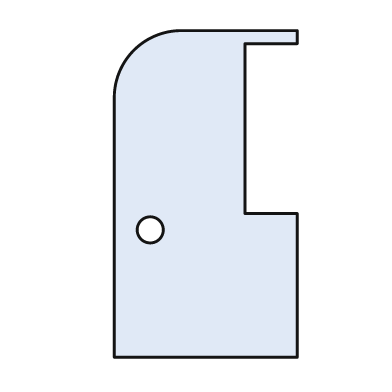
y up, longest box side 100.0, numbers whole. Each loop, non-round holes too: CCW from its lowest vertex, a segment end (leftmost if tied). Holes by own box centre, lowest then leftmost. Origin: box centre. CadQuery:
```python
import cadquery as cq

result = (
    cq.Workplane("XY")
    .moveTo(-28.0, -50.0)
    .lineTo(28.0, -50.0)
    .lineTo(28.0, -6.0)
    .lineTo(12.0, -6.0)
    .lineTo(12.0, 46.0)
    .lineTo(28.0, 46.0)
    .lineTo(28.0, 50.0)
    .lineTo(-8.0, 50.0)
    .threePointArc((-22.0, 44.0), (-28.0, 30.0))
    .close()
    .moveTo(-17.0, -11.0)
    .circle(4.0)
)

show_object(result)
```